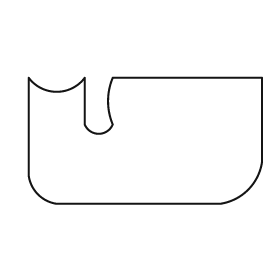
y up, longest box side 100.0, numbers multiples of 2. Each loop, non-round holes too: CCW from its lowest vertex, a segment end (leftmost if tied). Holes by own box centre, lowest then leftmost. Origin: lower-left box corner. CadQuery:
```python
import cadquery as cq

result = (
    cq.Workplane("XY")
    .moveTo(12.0, 0.0)
    .lineTo(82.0, 0.0)
    .threePointArc((94.0, 6.0), (100.0, 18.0))
    .lineTo(100.0, 54.0)
    .lineTo(36.0, 54.0)
    .threePointArc((34.0, 44.0), (36.0, 34.0))
    .threePointArc((30.0, 30.0), (24.0, 34.0))
    .lineTo(24.0, 54.0)
    .threePointArc((12.0, 48.0), (0.0, 54.0))
    .lineTo(0.0, 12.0)
    .threePointArc((4.0, 4.0), (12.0, 0.0))
    .close()
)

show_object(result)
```